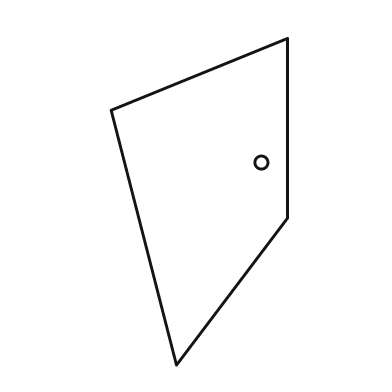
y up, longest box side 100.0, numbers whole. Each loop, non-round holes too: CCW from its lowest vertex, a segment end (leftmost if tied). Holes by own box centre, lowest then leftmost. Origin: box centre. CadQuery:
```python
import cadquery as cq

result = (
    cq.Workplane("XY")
    .moveTo(-7.0, -50.0)
    .lineTo(27.0, -5.0)
    .lineTo(27.0, 50.0)
    .lineTo(-27.0, 28.0)
    .close()
    .moveTo(19.0, 12.0)
    .circle(2.0)
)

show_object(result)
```